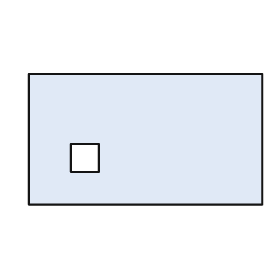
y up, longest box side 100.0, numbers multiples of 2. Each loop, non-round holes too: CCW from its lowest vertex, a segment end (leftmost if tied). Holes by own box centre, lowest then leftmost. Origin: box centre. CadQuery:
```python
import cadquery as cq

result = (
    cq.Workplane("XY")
    .moveTo(-50.0, -28.0)
    .lineTo(50.0, -28.0)
    .lineTo(50.0, 28.0)
    .lineTo(-50.0, 28.0)
    .close()
    .moveTo(-32.0, -14.0)
    .lineTo(-20.0, -14.0)
    .lineTo(-20.0, -2.0)
    .lineTo(-32.0, -2.0)
    .close()
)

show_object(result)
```